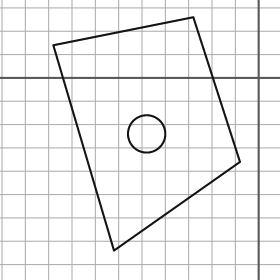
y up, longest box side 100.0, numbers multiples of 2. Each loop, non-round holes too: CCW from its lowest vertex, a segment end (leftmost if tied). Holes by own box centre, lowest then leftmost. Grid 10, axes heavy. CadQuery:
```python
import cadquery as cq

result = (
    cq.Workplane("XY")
    .moveTo(-62.0, -74.0)
    .lineTo(-8.0, -36.0)
    .lineTo(-28.0, 26.0)
    .lineTo(-88.0, 14.0)
    .close()
    .moveTo(-48.0, -24.0)
    .circle(8.0)
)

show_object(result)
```